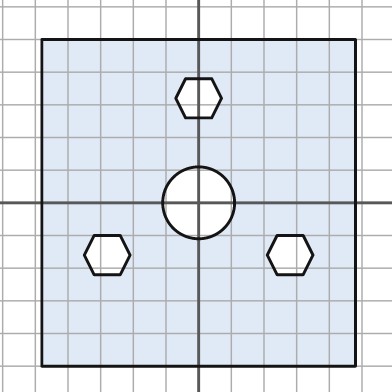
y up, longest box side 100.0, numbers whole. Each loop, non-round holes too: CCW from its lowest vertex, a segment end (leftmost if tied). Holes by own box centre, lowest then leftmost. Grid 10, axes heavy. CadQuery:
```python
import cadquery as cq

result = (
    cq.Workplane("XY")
    .moveTo(-48.0, -50.0)
    .lineTo(48.0, -50.0)
    .lineTo(48.0, 50.0)
    .lineTo(-48.0, 50.0)
    .close()
    .moveTo(-32.0, -22.0)
    .lineTo(-24.0, -22.0)
    .lineTo(-21.0, -16.0)
    .lineTo(-24.0, -10.0)
    .lineTo(-32.0, -10.0)
    .lineTo(-35.0, -16.0)
    .close()
    .moveTo(24.0, -22.0)
    .lineTo(32.0, -22.0)
    .lineTo(35.0, -16.0)
    .lineTo(32.0, -10.0)
    .lineTo(24.0, -10.0)
    .lineTo(21.0, -16.0)
    .close()
    .moveTo(0.0, 0.0)
    .circle(11.0)
    .moveTo(-4.0, 26.0)
    .lineTo(4.0, 26.0)
    .lineTo(7.0, 32.0)
    .lineTo(4.0, 38.0)
    .lineTo(-4.0, 38.0)
    .lineTo(-7.0, 32.0)
    .close()
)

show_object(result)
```